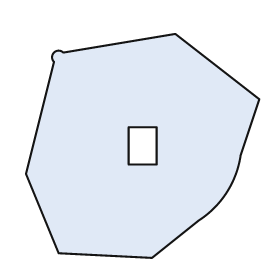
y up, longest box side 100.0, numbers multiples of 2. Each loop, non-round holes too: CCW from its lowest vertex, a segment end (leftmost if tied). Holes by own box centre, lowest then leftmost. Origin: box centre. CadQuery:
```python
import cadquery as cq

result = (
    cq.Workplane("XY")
    .moveTo(4.0, -48.0)
    .lineTo(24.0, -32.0)
    .threePointArc((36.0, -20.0), (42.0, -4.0))
    .lineTo(50.0, 20.0)
    .lineTo(14.0, 48.0)
    .lineTo(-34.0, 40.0)
    .threePointArc((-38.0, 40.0), (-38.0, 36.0))
    .lineTo(-50.0, -12.0)
    .lineTo(-36.0, -46.0)
    .close()
    .moveTo(-6.0, -8.0)
    .lineTo(6.0, -8.0)
    .lineTo(6.0, 8.0)
    .lineTo(-6.0, 8.0)
    .close()
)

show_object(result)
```